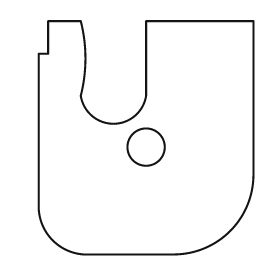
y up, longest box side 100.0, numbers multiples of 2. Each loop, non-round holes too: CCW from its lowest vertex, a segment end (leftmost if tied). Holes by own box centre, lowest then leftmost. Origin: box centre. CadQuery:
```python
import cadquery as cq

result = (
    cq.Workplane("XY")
    .moveTo(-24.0, -50.0)
    .lineTo(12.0, -50.0)
    .threePointArc((36.0, -40.0), (46.0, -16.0))
    .lineTo(46.0, 50.0)
    .lineTo(0.0, 50.0)
    .lineTo(0.0, 18.0)
    .threePointArc((-14.0, 6.0), (-28.0, 18.0))
    .threePointArc((-26.0, 34.0), (-28.0, 50.0))
    .lineTo(-42.0, 50.0)
    .lineTo(-42.0, 36.0)
    .lineTo(-46.0, 36.0)
    .lineTo(-46.0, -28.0)
    .threePointArc((-40.0, -44.0), (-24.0, -50.0))
    .close()
    .moveTo(0.0, -4.0)
    .circle(8.0)
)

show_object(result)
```